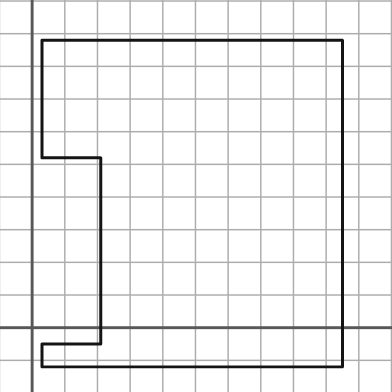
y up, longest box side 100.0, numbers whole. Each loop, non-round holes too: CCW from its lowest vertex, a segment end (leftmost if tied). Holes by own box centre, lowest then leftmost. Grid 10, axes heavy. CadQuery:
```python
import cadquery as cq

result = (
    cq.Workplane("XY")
    .moveTo(3.0, -12.0)
    .lineTo(95.0, -12.0)
    .lineTo(95.0, 88.0)
    .lineTo(3.0, 88.0)
    .lineTo(3.0, 52.0)
    .lineTo(21.0, 52.0)
    .lineTo(21.0, -5.0)
    .lineTo(3.0, -5.0)
    .close()
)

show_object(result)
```